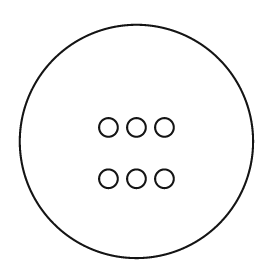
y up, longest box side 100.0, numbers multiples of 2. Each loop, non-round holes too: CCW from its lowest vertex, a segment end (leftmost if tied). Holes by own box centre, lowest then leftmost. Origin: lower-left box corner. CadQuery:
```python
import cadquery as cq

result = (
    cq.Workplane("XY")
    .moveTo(50.0, 50.0)
    .circle(50.0)
    .moveTo(38.0, 34.0)
    .circle(4.0)
    .moveTo(50.0, 34.0)
    .circle(4.0)
    .moveTo(62.0, 34.0)
    .circle(4.0)
    .moveTo(38.0, 56.0)
    .circle(4.0)
    .moveTo(50.0, 56.0)
    .circle(4.0)
    .moveTo(62.0, 56.0)
    .circle(4.0)
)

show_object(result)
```